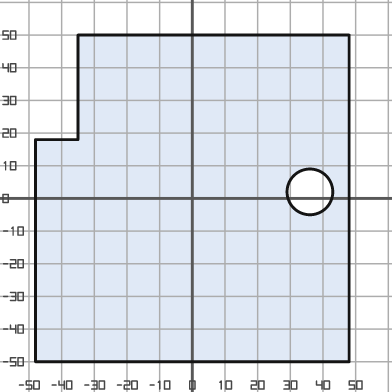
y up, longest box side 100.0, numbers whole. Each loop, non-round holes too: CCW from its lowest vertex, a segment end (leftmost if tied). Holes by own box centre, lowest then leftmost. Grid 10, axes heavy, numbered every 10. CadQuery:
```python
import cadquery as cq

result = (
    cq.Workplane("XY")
    .moveTo(-48.0, -50.0)
    .lineTo(48.0, -50.0)
    .lineTo(48.0, 50.0)
    .lineTo(-35.0, 50.0)
    .lineTo(-35.0, 18.0)
    .lineTo(-48.0, 18.0)
    .close()
    .moveTo(36.0, 2.0)
    .circle(7.0)
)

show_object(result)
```